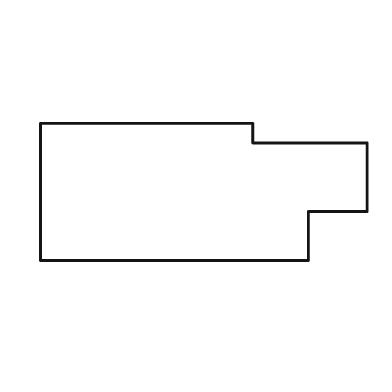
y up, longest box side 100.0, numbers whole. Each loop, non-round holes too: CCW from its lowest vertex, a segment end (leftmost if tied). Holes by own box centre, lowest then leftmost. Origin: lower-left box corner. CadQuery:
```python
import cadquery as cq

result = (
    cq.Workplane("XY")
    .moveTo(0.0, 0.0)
    .lineTo(82.0, 0.0)
    .lineTo(82.0, 15.0)
    .lineTo(100.0, 15.0)
    .lineTo(100.0, 36.0)
    .lineTo(65.0, 36.0)
    .lineTo(65.0, 42.0)
    .lineTo(0.0, 42.0)
    .close()
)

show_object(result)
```